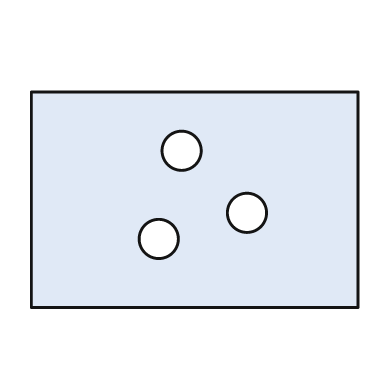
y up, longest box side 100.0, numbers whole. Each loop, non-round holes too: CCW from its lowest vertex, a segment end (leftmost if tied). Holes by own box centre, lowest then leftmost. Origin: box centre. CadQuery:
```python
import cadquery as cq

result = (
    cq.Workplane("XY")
    .moveTo(-50.0, -33.0)
    .lineTo(50.0, -33.0)
    .lineTo(50.0, 33.0)
    .lineTo(-50.0, 33.0)
    .close()
    .moveTo(-11.0, -12.0)
    .circle(6.0)
    .moveTo(16.0, -4.0)
    .circle(6.0)
    .moveTo(-4.0, 15.0)
    .circle(6.0)
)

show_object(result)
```